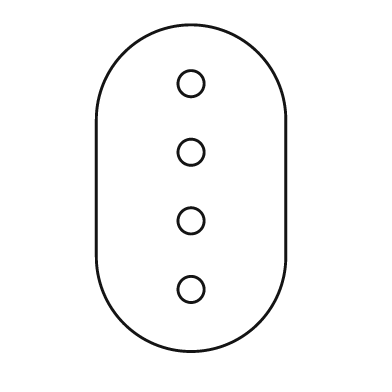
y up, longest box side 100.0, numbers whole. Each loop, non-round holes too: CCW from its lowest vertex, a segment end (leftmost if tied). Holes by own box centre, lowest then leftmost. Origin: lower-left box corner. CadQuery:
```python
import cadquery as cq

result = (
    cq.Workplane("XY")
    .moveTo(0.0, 29.0)
    .threePointArc((29.0, 0.0), (58.0, 29.0))
    .lineTo(58.0, 71.0)
    .threePointArc((29.0, 100.0), (0.0, 71.0))
    .close()
    .moveTo(29.0, 19.0)
    .circle(4.0)
    .moveTo(29.0, 40.0)
    .circle(4.0)
    .moveTo(29.0, 61.0)
    .circle(4.0)
    .moveTo(29.0, 82.0)
    .circle(4.0)
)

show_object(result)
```